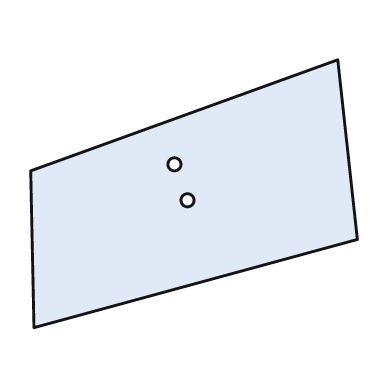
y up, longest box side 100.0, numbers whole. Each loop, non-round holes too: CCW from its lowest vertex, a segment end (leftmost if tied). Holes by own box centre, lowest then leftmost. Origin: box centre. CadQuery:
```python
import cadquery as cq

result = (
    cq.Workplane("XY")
    .moveTo(-49.0, -41.0)
    .lineTo(50.0, -14.0)
    .lineTo(44.0, 41.0)
    .lineTo(-50.0, 7.0)
    .close()
    .moveTo(-2.0, -2.0)
    .circle(2.0)
    .moveTo(-6.0, 9.0)
    .circle(2.0)
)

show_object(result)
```